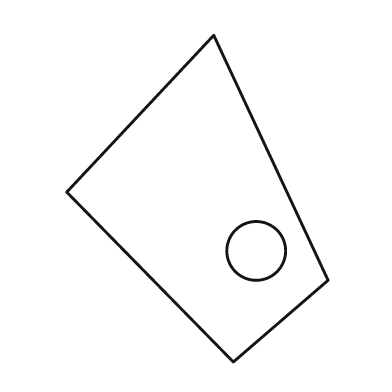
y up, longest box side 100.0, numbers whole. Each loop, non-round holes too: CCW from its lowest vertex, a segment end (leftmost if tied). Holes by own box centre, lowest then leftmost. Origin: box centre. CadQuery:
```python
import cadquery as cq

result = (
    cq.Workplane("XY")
    .moveTo(11.0, -50.0)
    .lineTo(40.0, -25.0)
    .lineTo(5.0, 50.0)
    .lineTo(-40.0, 2.0)
    .close()
    .moveTo(18.0, -16.0)
    .circle(9.0)
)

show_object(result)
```